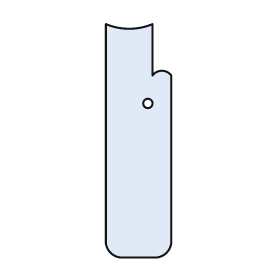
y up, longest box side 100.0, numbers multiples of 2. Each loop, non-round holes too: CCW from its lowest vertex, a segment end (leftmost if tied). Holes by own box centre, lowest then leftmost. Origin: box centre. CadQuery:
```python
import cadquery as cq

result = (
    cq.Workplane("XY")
    .moveTo(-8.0, -50.0)
    .lineTo(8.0, -50.0)
    .threePointArc((12.0, -48.0), (14.0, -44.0))
    .lineTo(14.0, 28.0)
    .threePointArc((10.0, 30.0), (6.0, 28.0))
    .lineTo(6.0, 50.0)
    .threePointArc((-4.0, 48.0), (-14.0, 50.0))
    .lineTo(-14.0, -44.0)
    .threePointArc((-12.0, -48.0), (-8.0, -50.0))
    .close()
    .moveTo(4.0, 16.0)
    .circle(2.0)
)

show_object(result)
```